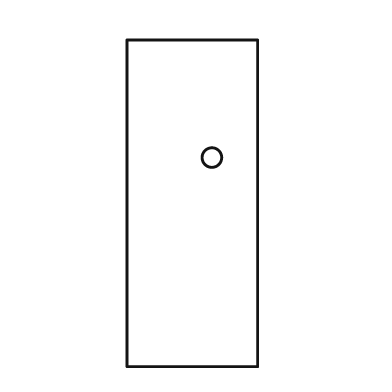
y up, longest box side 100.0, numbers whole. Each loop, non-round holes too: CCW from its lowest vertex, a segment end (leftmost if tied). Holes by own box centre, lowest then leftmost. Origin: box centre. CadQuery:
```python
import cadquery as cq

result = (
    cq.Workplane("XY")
    .moveTo(-20.0, -50.0)
    .lineTo(20.0, -50.0)
    .lineTo(20.0, 50.0)
    .lineTo(-20.0, 50.0)
    .close()
    .moveTo(6.0, 14.0)
    .circle(3.0)
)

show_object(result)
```